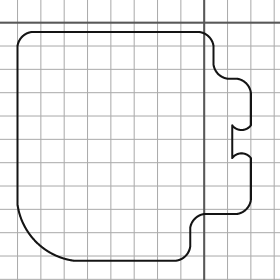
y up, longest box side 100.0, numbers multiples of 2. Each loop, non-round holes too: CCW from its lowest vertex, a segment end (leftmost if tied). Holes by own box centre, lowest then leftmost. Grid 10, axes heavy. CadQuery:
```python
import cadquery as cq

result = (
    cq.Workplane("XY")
    .moveTo(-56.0, -102.0)
    .lineTo(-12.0, -102.0)
    .threePointArc((-8.0, -100.0), (-6.0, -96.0))
    .lineTo(-6.0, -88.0)
    .threePointArc((-4.0, -84.0), (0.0, -82.0))
    .lineTo(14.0, -82.0)
    .threePointArc((18.0, -80.0), (20.0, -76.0))
    .lineTo(20.0, -58.0)
    .threePointArc((16.0, -56.0), (12.0, -58.0))
    .lineTo(12.0, -44.0)
    .threePointArc((16.0, -46.0), (20.0, -44.0))
    .lineTo(20.0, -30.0)
    .threePointArc((18.0, -26.0), (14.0, -24.0))
    .lineTo(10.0, -24.0)
    .threePointArc((6.0, -22.0), (4.0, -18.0))
    .lineTo(4.0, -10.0)
    .threePointArc((2.0, -6.0), (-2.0, -4.0))
    .lineTo(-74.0, -4.0)
    .threePointArc((-78.0, -6.0), (-80.0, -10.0))
    .lineTo(-80.0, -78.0)
    .threePointArc((-72.0, -94.0), (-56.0, -102.0))
    .close()
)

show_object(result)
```